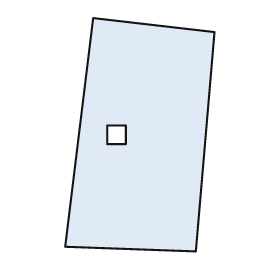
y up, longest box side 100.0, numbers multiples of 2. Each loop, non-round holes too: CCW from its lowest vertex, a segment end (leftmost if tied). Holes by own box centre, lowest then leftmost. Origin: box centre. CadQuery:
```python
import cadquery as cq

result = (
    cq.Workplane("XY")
    .moveTo(24.0, -50.0)
    .lineTo(32.0, 44.0)
    .lineTo(-20.0, 50.0)
    .lineTo(-32.0, -48.0)
    .close()
    .moveTo(-14.0, -4.0)
    .lineTo(-6.0, -4.0)
    .lineTo(-6.0, 4.0)
    .lineTo(-14.0, 4.0)
    .close()
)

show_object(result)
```